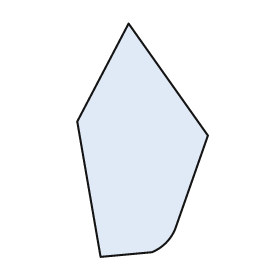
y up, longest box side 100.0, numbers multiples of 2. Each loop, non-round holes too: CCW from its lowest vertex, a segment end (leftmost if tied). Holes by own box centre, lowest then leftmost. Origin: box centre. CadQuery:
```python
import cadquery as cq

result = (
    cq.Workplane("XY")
    .moveTo(-18.0, -50.0)
    .lineTo(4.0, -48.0)
    .threePointArc((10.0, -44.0), (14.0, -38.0))
    .lineTo(28.0, 2.0)
    .lineTo(-6.0, 50.0)
    .lineTo(-28.0, 8.0)
    .close()
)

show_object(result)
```